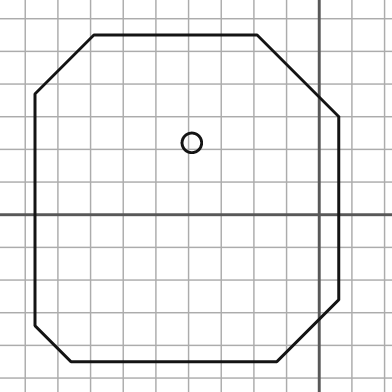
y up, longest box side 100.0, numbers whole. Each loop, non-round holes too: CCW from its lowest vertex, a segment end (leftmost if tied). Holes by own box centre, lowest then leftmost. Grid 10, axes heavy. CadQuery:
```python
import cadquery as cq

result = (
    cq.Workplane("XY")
    .moveTo(-76.0, -45.0)
    .lineTo(-13.0, -45.0)
    .lineTo(6.0, -26.0)
    .lineTo(6.0, 30.0)
    .lineTo(-19.0, 55.0)
    .lineTo(-69.0, 55.0)
    .lineTo(-87.0, 37.0)
    .lineTo(-87.0, -34.0)
    .close()
    .moveTo(-39.0, 22.0)
    .circle(3.0)
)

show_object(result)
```